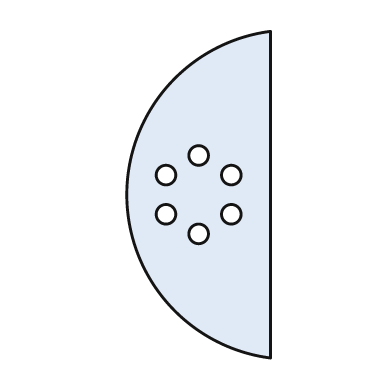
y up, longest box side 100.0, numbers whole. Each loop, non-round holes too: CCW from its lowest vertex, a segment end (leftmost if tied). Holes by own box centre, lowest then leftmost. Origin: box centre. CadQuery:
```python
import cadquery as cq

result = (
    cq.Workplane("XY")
    .moveTo(22.0, -50.0)
    .lineTo(22.0, 50.0)
    .threePointArc((-22.0, 0.0), (22.0, -50.0))
    .close()
    .moveTo(0.0, -12.0)
    .circle(3.0)
    .moveTo(-10.0, -6.0)
    .circle(3.0)
    .moveTo(10.0, -6.0)
    .circle(3.0)
    .moveTo(-10.0, 6.0)
    .circle(3.0)
    .moveTo(10.0, 6.0)
    .circle(3.0)
    .moveTo(0.0, 12.0)
    .circle(3.0)
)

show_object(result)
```